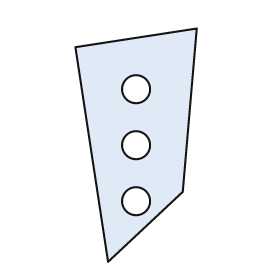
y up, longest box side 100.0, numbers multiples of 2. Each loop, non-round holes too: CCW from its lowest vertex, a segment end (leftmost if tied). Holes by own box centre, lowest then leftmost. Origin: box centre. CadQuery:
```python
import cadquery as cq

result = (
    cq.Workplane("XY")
    .moveTo(-12.0, -50.0)
    .lineTo(20.0, -20.0)
    .lineTo(26.0, 50.0)
    .lineTo(-26.0, 42.0)
    .close()
    .moveTo(0.0, -24.0)
    .circle(6.0)
    .moveTo(0.0, 0.0)
    .circle(6.0)
    .moveTo(0.0, 24.0)
    .circle(6.0)
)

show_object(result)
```